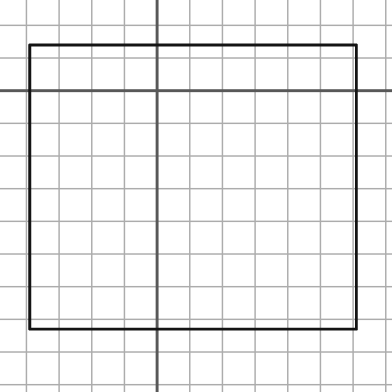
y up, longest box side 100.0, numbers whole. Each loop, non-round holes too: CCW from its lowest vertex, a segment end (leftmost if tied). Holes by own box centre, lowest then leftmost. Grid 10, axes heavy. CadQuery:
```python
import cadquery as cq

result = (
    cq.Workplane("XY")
    .moveTo(-39.0, -73.0)
    .lineTo(61.0, -73.0)
    .lineTo(61.0, 14.0)
    .lineTo(-39.0, 14.0)
    .close()
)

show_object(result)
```